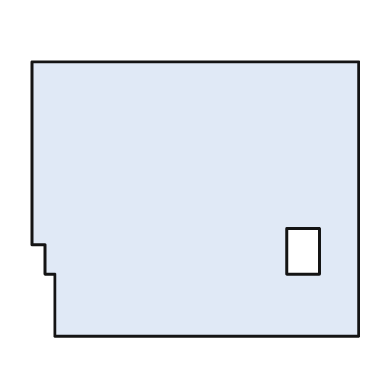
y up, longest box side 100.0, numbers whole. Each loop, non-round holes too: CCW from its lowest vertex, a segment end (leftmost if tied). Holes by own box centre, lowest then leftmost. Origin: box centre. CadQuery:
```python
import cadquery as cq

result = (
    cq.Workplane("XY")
    .moveTo(-43.0, -42.0)
    .lineTo(50.0, -42.0)
    .lineTo(50.0, 42.0)
    .lineTo(-50.0, 42.0)
    .lineTo(-50.0, -14.0)
    .lineTo(-46.0, -14.0)
    .lineTo(-46.0, -23.0)
    .lineTo(-43.0, -23.0)
    .close()
    .moveTo(28.0, -23.0)
    .lineTo(38.0, -23.0)
    .lineTo(38.0, -9.0)
    .lineTo(28.0, -9.0)
    .close()
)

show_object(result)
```